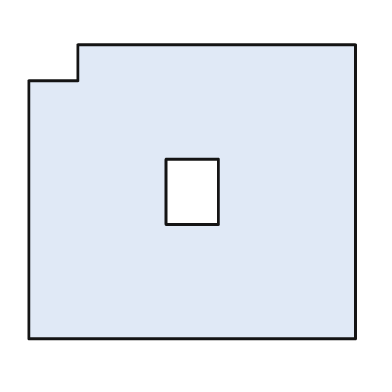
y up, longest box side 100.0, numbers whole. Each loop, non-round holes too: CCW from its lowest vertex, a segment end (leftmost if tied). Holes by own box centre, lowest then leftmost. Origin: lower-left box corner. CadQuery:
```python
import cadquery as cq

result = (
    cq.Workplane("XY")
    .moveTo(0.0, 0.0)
    .lineTo(100.0, 0.0)
    .lineTo(100.0, 90.0)
    .lineTo(15.0, 90.0)
    .lineTo(15.0, 79.0)
    .lineTo(0.0, 79.0)
    .close()
    .moveTo(42.0, 35.0)
    .lineTo(58.0, 35.0)
    .lineTo(58.0, 55.0)
    .lineTo(42.0, 55.0)
    .close()
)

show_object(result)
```